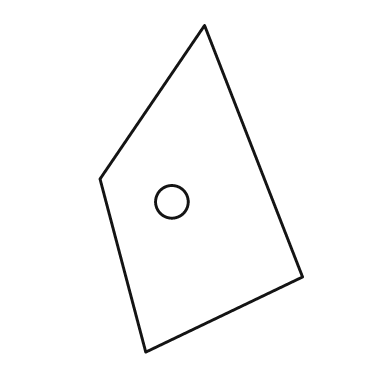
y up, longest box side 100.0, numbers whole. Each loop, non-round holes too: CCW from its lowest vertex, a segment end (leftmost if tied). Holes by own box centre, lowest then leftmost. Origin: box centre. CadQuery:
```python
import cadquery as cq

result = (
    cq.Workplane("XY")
    .moveTo(-17.0, -50.0)
    .lineTo(31.0, -27.0)
    .lineTo(1.0, 50.0)
    .lineTo(-31.0, 3.0)
    .close()
    .moveTo(-9.0, -4.0)
    .circle(5.0)
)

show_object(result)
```